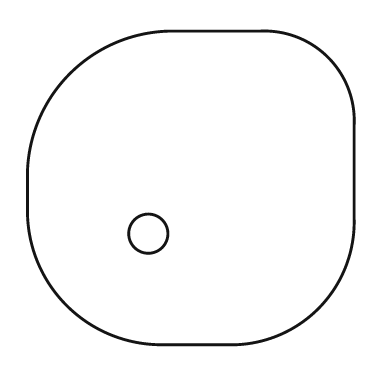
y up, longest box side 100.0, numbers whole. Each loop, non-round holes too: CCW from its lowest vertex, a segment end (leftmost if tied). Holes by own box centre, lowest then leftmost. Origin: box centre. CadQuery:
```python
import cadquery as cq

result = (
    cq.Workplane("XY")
    .moveTo(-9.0, -48.0)
    .lineTo(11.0, -48.0)
    .threePointArc((39.0, -37.0), (50.0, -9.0))
    .lineTo(50.0, 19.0)
    .threePointArc((42.0, 40.0), (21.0, 48.0))
    .lineTo(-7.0, 48.0)
    .threePointArc((-37.0, 35.0), (-50.0, 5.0))
    .lineTo(-50.0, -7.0)
    .threePointArc((-38.0, -36.0), (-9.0, -48.0))
    .close()
    .moveTo(-13.0, -14.0)
    .circle(6.0)
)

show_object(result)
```